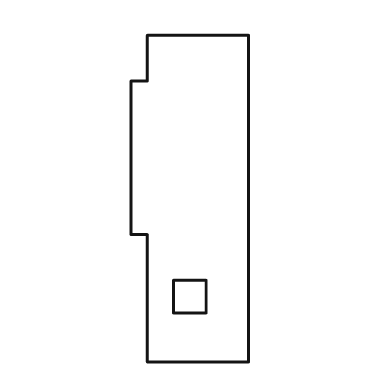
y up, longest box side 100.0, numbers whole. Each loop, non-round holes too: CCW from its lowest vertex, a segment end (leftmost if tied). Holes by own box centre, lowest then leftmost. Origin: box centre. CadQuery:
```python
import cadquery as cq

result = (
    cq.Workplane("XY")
    .moveTo(-13.0, -50.0)
    .lineTo(18.0, -50.0)
    .lineTo(18.0, 50.0)
    .lineTo(-13.0, 50.0)
    .lineTo(-13.0, 36.0)
    .lineTo(-18.0, 36.0)
    .lineTo(-18.0, -11.0)
    .lineTo(-13.0, -11.0)
    .close()
    .moveTo(-5.0, -35.0)
    .lineTo(5.0, -35.0)
    .lineTo(5.0, -25.0)
    .lineTo(-5.0, -25.0)
    .close()
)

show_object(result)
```